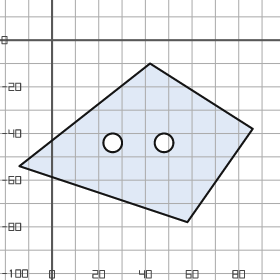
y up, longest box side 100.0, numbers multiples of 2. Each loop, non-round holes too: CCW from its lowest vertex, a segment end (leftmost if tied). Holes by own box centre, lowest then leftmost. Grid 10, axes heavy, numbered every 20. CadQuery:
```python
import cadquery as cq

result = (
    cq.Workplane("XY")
    .moveTo(58.0, -78.0)
    .lineTo(86.0, -38.0)
    .lineTo(42.0, -10.0)
    .lineTo(-14.0, -54.0)
    .close()
    .moveTo(26.0, -44.0)
    .circle(4.0)
    .moveTo(48.0, -44.0)
    .circle(4.0)
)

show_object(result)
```